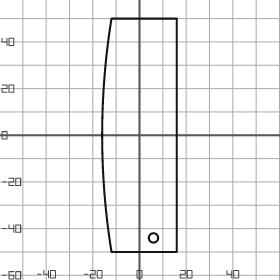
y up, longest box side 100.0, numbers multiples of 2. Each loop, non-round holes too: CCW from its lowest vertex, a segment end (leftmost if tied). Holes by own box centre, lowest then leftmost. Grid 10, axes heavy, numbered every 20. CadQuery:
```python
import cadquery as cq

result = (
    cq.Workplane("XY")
    .moveTo(-12.0, -50.0)
    .lineTo(16.0, -50.0)
    .lineTo(16.0, 50.0)
    .lineTo(-12.0, 50.0)
    .threePointArc((-16.0, 0.0), (-12.0, -50.0))
    .close()
    .moveTo(6.0, -44.0)
    .circle(2.0)
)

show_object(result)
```